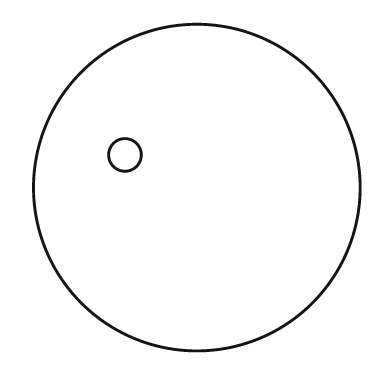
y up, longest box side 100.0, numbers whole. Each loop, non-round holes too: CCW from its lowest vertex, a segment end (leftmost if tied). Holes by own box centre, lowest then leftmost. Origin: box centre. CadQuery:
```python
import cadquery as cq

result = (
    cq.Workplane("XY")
    .moveTo(0.0, 0.0)
    .circle(50.0)
    .moveTo(-22.0, 10.0)
    .circle(5.0)
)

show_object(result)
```